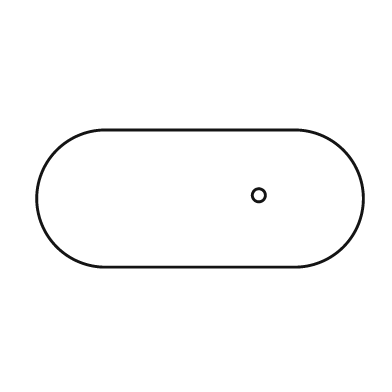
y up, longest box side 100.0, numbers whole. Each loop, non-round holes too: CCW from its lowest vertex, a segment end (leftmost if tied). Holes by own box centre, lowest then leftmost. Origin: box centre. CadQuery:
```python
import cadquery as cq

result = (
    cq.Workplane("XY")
    .moveTo(-29.0, -21.0)
    .lineTo(29.0, -21.0)
    .threePointArc((50.0, 0.0), (29.0, 21.0))
    .lineTo(-29.0, 21.0)
    .threePointArc((-50.0, 0.0), (-29.0, -21.0))
    .close()
    .moveTo(18.0, 1.0)
    .circle(2.0)
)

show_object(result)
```